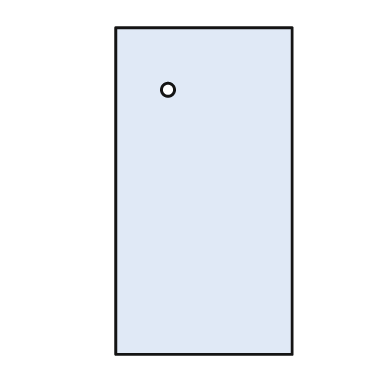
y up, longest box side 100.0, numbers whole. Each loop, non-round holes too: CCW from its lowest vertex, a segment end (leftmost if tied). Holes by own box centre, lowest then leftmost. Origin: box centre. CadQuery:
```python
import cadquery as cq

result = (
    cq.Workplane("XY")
    .moveTo(-27.0, -50.0)
    .lineTo(27.0, -50.0)
    .lineTo(27.0, 50.0)
    .lineTo(-27.0, 50.0)
    .close()
    .moveTo(-11.0, 31.0)
    .circle(2.0)
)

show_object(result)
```